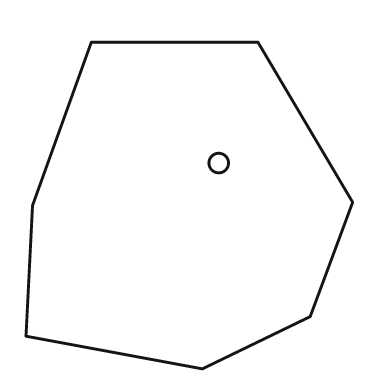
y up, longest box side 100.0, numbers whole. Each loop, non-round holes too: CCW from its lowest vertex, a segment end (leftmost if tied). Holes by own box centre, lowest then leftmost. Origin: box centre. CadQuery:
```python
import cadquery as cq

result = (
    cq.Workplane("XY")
    .moveTo(4.0, -50.0)
    .lineTo(37.0, -34.0)
    .lineTo(50.0, 1.0)
    .lineTo(21.0, 50.0)
    .lineTo(-30.0, 50.0)
    .lineTo(-48.0, 0.0)
    .lineTo(-50.0, -40.0)
    .close()
    .moveTo(9.0, 13.0)
    .circle(3.0)
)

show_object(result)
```